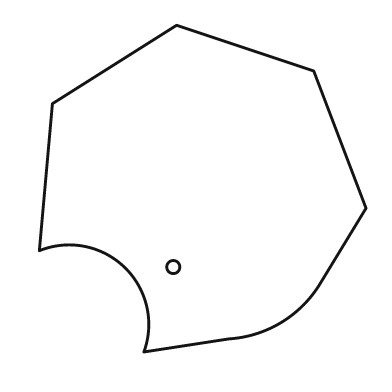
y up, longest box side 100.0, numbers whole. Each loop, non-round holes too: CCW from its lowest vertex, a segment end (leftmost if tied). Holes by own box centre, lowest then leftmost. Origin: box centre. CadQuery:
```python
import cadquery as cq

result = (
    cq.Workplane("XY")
    .moveTo(-18.0, -50.0)
    .lineTo(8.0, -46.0)
    .threePointArc((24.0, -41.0), (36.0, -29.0))
    .lineTo(50.0, -6.0)
    .lineTo(34.0, 36.0)
    .lineTo(-8.0, 50.0)
    .lineTo(-46.0, 26.0)
    .lineTo(-50.0, -19.0)
    .threePointArc((-24.0, -24.0), (-18.0, -50.0))
    .close()
    .moveTo(-9.0, -24.0)
    .circle(2.0)
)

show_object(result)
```